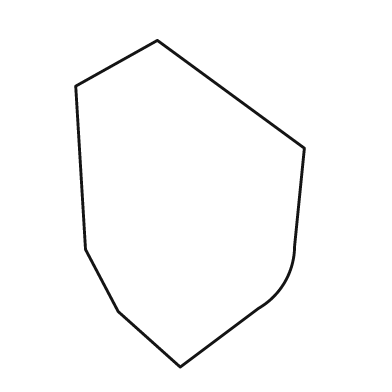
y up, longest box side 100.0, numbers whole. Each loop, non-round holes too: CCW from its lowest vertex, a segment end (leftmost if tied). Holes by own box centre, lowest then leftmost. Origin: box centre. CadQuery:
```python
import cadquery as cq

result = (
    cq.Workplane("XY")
    .moveTo(-3.0, -50.0)
    .lineTo(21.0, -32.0)
    .threePointArc((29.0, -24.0), (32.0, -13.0))
    .lineTo(35.0, 17.0)
    .lineTo(-10.0, 50.0)
    .lineTo(-35.0, 36.0)
    .lineTo(-32.0, -14.0)
    .lineTo(-22.0, -33.0)
    .close()
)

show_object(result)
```